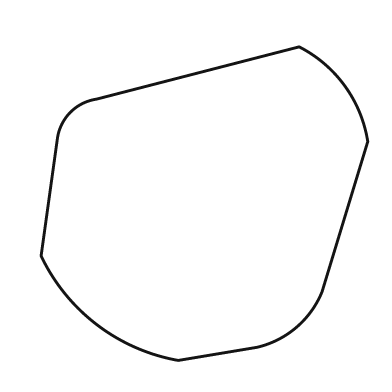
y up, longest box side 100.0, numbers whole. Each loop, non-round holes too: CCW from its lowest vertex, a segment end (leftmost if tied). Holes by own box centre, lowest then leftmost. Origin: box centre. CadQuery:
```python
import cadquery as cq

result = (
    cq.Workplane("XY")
    .moveTo(-8.0, -48.0)
    .lineTo(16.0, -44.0)
    .threePointArc((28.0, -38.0), (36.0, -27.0))
    .lineTo(50.0, 19.0)
    .threePointArc((43.0, 36.0), (29.0, 48.0))
    .lineTo(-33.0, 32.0)
    .threePointArc((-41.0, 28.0), (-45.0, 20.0))
    .lineTo(-50.0, -16.0)
    .threePointArc((-33.0, -37.0), (-8.0, -48.0))
    .close()
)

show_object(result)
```